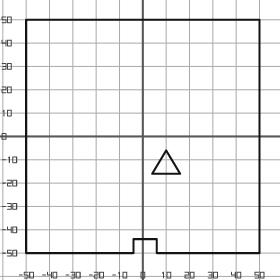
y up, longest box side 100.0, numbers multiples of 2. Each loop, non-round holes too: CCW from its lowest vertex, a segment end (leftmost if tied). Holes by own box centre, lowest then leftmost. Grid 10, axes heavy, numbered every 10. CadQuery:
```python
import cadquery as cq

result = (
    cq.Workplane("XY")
    .moveTo(-50.0, -50.0)
    .lineTo(-4.0, -50.0)
    .lineTo(-4.0, -44.0)
    .lineTo(6.0, -44.0)
    .lineTo(6.0, -50.0)
    .lineTo(50.0, -50.0)
    .lineTo(50.0, 50.0)
    .lineTo(-50.0, 50.0)
    .close()
    .moveTo(4.0, -16.0)
    .lineTo(16.0, -16.0)
    .lineTo(10.0, -6.0)
    .close()
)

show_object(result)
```